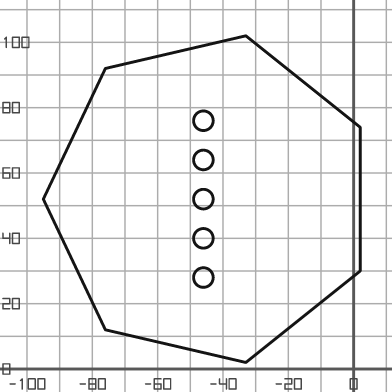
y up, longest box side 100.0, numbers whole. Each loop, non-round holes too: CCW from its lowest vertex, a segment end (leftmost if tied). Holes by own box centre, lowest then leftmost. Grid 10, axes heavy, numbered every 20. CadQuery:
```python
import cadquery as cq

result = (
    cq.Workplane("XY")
    .moveTo(-33.0, 2.0)
    .lineTo(2.0, 30.0)
    .lineTo(2.0, 74.0)
    .lineTo(-33.0, 102.0)
    .lineTo(-76.0, 92.0)
    .lineTo(-95.0, 52.0)
    .lineTo(-76.0, 12.0)
    .close()
    .moveTo(-46.0, 28.0)
    .circle(3.0)
    .moveTo(-46.0, 40.0)
    .circle(3.0)
    .moveTo(-46.0, 52.0)
    .circle(3.0)
    .moveTo(-46.0, 64.0)
    .circle(3.0)
    .moveTo(-46.0, 76.0)
    .circle(3.0)
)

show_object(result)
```